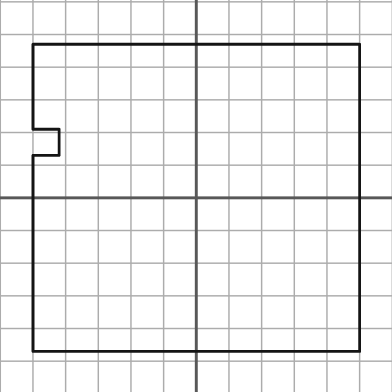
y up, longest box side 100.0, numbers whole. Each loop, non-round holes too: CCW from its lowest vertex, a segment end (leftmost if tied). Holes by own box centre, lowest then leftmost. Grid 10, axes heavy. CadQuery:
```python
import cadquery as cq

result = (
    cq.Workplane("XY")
    .moveTo(-50.0, -47.0)
    .lineTo(50.0, -47.0)
    .lineTo(50.0, 47.0)
    .lineTo(-50.0, 47.0)
    .lineTo(-50.0, 21.0)
    .lineTo(-42.0, 21.0)
    .lineTo(-42.0, 13.0)
    .lineTo(-50.0, 13.0)
    .close()
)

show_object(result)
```